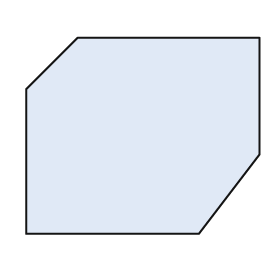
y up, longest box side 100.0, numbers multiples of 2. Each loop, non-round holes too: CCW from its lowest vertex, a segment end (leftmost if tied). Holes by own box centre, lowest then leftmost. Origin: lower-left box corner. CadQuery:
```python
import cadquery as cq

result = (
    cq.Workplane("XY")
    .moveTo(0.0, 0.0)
    .lineTo(74.0, 0.0)
    .lineTo(100.0, 34.0)
    .lineTo(100.0, 84.0)
    .lineTo(22.0, 84.0)
    .lineTo(0.0, 62.0)
    .close()
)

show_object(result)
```